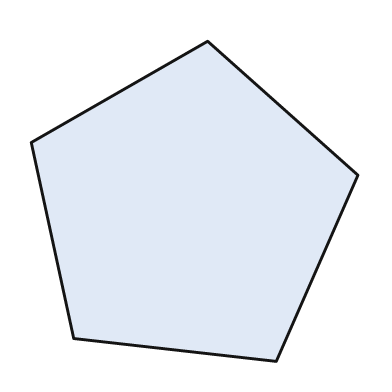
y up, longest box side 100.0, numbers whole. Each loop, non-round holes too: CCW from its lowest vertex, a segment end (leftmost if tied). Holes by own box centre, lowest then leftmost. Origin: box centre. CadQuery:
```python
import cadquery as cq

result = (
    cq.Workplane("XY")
    .moveTo(25.0, -49.0)
    .lineTo(50.0, 8.0)
    .lineTo(4.0, 49.0)
    .lineTo(-50.0, 18.0)
    .lineTo(-37.0, -42.0)
    .close()
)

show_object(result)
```